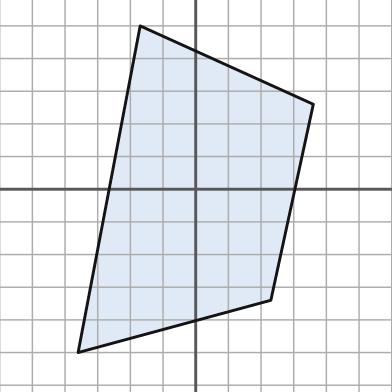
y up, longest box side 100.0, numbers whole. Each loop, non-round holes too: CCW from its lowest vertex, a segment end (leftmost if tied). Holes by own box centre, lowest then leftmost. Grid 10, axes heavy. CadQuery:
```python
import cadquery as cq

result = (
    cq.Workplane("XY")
    .moveTo(-36.0, -50.0)
    .lineTo(23.0, -34.0)
    .lineTo(36.0, 26.0)
    .lineTo(-17.0, 50.0)
    .close()
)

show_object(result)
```